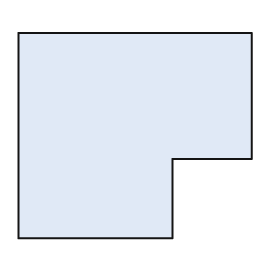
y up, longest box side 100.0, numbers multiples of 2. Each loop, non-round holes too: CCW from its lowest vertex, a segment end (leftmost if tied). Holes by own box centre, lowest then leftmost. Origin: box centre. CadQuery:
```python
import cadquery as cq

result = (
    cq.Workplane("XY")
    .moveTo(-50.0, -44.0)
    .lineTo(16.0, -44.0)
    .lineTo(16.0, -10.0)
    .lineTo(50.0, -10.0)
    .lineTo(50.0, 44.0)
    .lineTo(-50.0, 44.0)
    .close()
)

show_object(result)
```